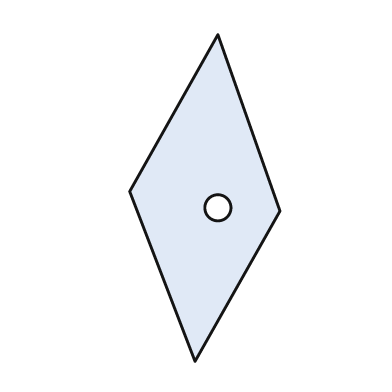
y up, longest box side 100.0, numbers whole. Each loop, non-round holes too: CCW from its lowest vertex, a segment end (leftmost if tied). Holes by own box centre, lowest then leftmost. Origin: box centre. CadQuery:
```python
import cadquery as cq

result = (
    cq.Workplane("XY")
    .moveTo(-3.0, -50.0)
    .lineTo(23.0, -4.0)
    .lineTo(4.0, 50.0)
    .lineTo(-23.0, 2.0)
    .close()
    .moveTo(4.0, -3.0)
    .circle(4.0)
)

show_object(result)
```